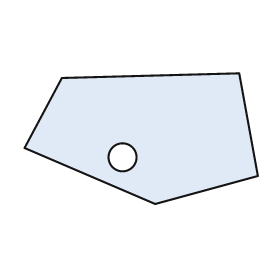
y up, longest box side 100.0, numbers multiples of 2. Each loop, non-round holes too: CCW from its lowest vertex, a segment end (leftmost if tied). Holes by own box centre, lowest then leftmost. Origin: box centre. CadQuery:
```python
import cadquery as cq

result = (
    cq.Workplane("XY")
    .moveTo(6.0, -28.0)
    .lineTo(50.0, -16.0)
    .lineTo(42.0, 28.0)
    .lineTo(-34.0, 26.0)
    .lineTo(-50.0, -4.0)
    .close()
    .moveTo(-8.0, -8.0)
    .circle(6.0)
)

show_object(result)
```